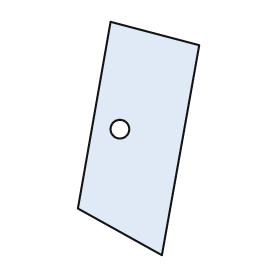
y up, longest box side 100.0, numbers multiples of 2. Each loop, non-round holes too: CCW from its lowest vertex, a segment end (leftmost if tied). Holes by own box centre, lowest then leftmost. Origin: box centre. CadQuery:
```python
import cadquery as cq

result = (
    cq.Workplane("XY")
    .moveTo(10.0, -50.0)
    .lineTo(26.0, 40.0)
    .lineTo(-12.0, 50.0)
    .lineTo(-26.0, -30.0)
    .close()
    .moveTo(-8.0, 4.0)
    .circle(4.0)
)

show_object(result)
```